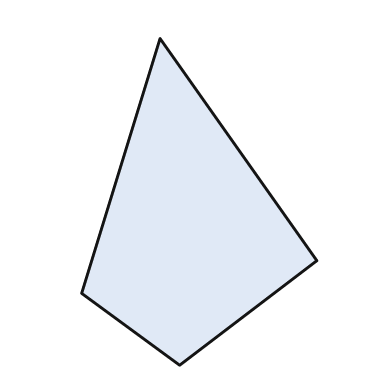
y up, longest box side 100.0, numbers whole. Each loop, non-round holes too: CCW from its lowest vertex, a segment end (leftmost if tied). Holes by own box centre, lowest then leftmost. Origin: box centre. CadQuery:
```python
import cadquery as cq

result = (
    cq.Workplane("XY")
    .moveTo(-6.0, -50.0)
    .lineTo(36.0, -18.0)
    .lineTo(-12.0, 50.0)
    .lineTo(-36.0, -28.0)
    .close()
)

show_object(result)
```